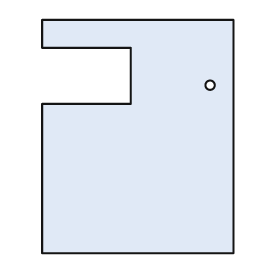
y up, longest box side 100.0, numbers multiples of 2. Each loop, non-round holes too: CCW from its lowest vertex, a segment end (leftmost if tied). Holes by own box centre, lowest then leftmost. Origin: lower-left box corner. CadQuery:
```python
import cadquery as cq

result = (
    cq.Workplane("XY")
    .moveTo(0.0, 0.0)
    .lineTo(82.0, 0.0)
    .lineTo(82.0, 100.0)
    .lineTo(0.0, 100.0)
    .lineTo(0.0, 88.0)
    .lineTo(38.0, 88.0)
    .lineTo(38.0, 64.0)
    .lineTo(0.0, 64.0)
    .close()
    .moveTo(72.0, 72.0)
    .circle(2.0)
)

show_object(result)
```